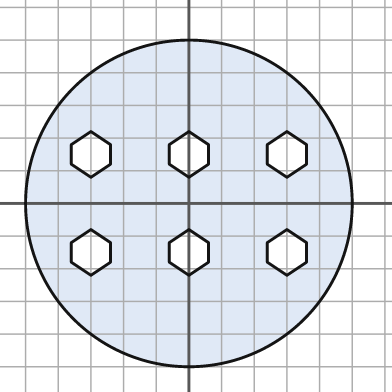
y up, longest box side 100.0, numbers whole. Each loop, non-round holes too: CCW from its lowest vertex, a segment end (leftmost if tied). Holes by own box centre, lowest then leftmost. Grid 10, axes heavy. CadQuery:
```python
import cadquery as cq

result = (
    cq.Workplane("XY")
    .moveTo(0.0, 0.0)
    .circle(50.0)
    .moveTo(-30.0, -22.0)
    .lineTo(-24.0, -18.0)
    .lineTo(-24.0, -12.0)
    .lineTo(-30.0, -8.0)
    .lineTo(-36.0, -12.0)
    .lineTo(-36.0, -18.0)
    .close()
    .moveTo(0.0, -22.0)
    .lineTo(6.0, -18.0)
    .lineTo(6.0, -12.0)
    .lineTo(0.0, -8.0)
    .lineTo(-6.0, -12.0)
    .lineTo(-6.0, -18.0)
    .close()
    .moveTo(30.0, -22.0)
    .lineTo(36.0, -18.0)
    .lineTo(36.0, -12.0)
    .lineTo(30.0, -8.0)
    .lineTo(24.0, -12.0)
    .lineTo(24.0, -18.0)
    .close()
    .moveTo(-30.0, 8.0)
    .lineTo(-24.0, 12.0)
    .lineTo(-24.0, 18.0)
    .lineTo(-30.0, 22.0)
    .lineTo(-36.0, 18.0)
    .lineTo(-36.0, 12.0)
    .close()
    .moveTo(0.0, 8.0)
    .lineTo(6.0, 12.0)
    .lineTo(6.0, 18.0)
    .lineTo(0.0, 22.0)
    .lineTo(-6.0, 18.0)
    .lineTo(-6.0, 12.0)
    .close()
    .moveTo(30.0, 8.0)
    .lineTo(36.0, 12.0)
    .lineTo(36.0, 18.0)
    .lineTo(30.0, 22.0)
    .lineTo(24.0, 18.0)
    .lineTo(24.0, 12.0)
    .close()
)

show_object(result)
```